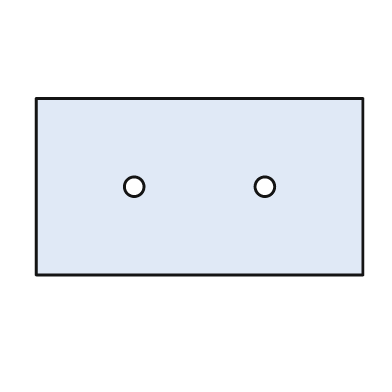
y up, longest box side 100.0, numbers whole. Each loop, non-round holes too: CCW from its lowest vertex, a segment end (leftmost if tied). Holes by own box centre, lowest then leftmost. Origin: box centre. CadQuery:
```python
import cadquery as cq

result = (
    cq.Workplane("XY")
    .moveTo(-50.0, -27.0)
    .lineTo(50.0, -27.0)
    .lineTo(50.0, 27.0)
    .lineTo(-50.0, 27.0)
    .close()
    .moveTo(-20.0, 0.0)
    .circle(3.0)
    .moveTo(20.0, 0.0)
    .circle(3.0)
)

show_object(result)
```